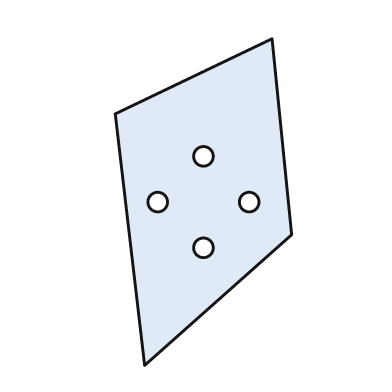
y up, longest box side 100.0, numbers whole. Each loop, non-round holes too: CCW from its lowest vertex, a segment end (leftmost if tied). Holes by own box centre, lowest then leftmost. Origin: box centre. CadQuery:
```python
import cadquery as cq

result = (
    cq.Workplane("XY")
    .moveTo(-18.0, -50.0)
    .lineTo(27.0, -10.0)
    .lineTo(21.0, 50.0)
    .lineTo(-27.0, 27.0)
    .close()
    .moveTo(0.0, -14.0)
    .circle(3.0)
    .moveTo(-14.0, 0.0)
    .circle(3.0)
    .moveTo(14.0, 0.0)
    .circle(3.0)
    .moveTo(0.0, 14.0)
    .circle(3.0)
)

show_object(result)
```